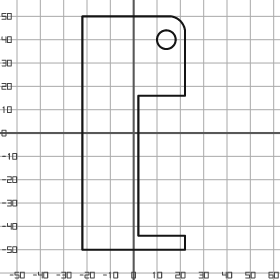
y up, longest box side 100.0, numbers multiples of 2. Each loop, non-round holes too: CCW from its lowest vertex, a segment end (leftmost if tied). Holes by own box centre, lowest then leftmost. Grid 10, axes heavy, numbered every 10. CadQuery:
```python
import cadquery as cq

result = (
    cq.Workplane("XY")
    .moveTo(-22.0, -50.0)
    .lineTo(22.0, -50.0)
    .lineTo(22.0, -44.0)
    .lineTo(2.0, -44.0)
    .lineTo(2.0, 16.0)
    .lineTo(22.0, 16.0)
    .lineTo(22.0, 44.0)
    .threePointArc((20.0, 48.0), (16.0, 50.0))
    .lineTo(-22.0, 50.0)
    .close()
    .moveTo(14.0, 40.0)
    .circle(4.0)
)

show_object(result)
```